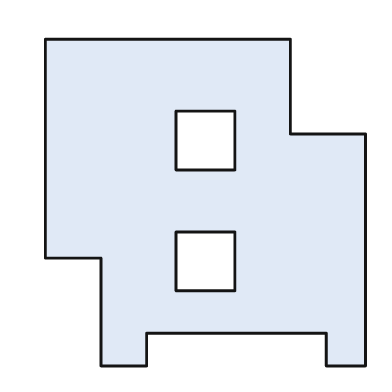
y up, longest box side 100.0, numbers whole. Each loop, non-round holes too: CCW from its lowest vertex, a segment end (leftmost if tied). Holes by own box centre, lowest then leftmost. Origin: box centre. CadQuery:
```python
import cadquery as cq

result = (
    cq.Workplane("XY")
    .moveTo(-32.0, -50.0)
    .lineTo(-18.0, -50.0)
    .lineTo(-18.0, -40.0)
    .lineTo(37.0, -40.0)
    .lineTo(37.0, -50.0)
    .lineTo(49.0, -50.0)
    .lineTo(49.0, 21.0)
    .lineTo(26.0, 21.0)
    .lineTo(26.0, 50.0)
    .lineTo(-49.0, 50.0)
    .lineTo(-49.0, -17.0)
    .lineTo(-32.0, -17.0)
    .close()
    .moveTo(-9.0, -27.0)
    .lineTo(9.0, -27.0)
    .lineTo(9.0, -9.0)
    .lineTo(-9.0, -9.0)
    .close()
    .moveTo(-9.0, 10.0)
    .lineTo(9.0, 10.0)
    .lineTo(9.0, 28.0)
    .lineTo(-9.0, 28.0)
    .close()
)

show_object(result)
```